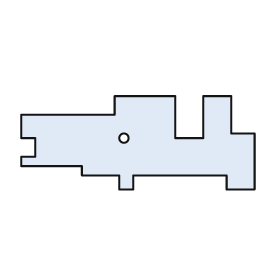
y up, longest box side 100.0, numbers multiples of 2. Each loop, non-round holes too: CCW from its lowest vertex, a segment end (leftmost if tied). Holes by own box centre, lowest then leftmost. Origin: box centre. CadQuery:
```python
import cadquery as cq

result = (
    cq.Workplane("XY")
    .moveTo(-8.0, -20.0)
    .lineTo(-2.0, -20.0)
    .lineTo(-2.0, -14.0)
    .lineTo(38.0, -14.0)
    .lineTo(38.0, -20.0)
    .lineTo(50.0, -20.0)
    .lineTo(50.0, 4.0)
    .lineTo(40.0, 4.0)
    .lineTo(40.0, 20.0)
    .lineTo(28.0, 20.0)
    .lineTo(28.0, 2.0)
    .lineTo(16.0, 2.0)
    .lineTo(16.0, 20.0)
    .lineTo(-10.0, 20.0)
    .lineTo(-10.0, 12.0)
    .lineTo(-50.0, 12.0)
    .lineTo(-50.0, 2.0)
    .lineTo(-44.0, 2.0)
    .lineTo(-44.0, -6.0)
    .lineTo(-50.0, -6.0)
    .lineTo(-50.0, -10.0)
    .lineTo(-24.0, -10.0)
    .lineTo(-24.0, -14.0)
    .lineTo(-8.0, -14.0)
    .close()
    .moveTo(-6.0, 2.0)
    .circle(2.0)
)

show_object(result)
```